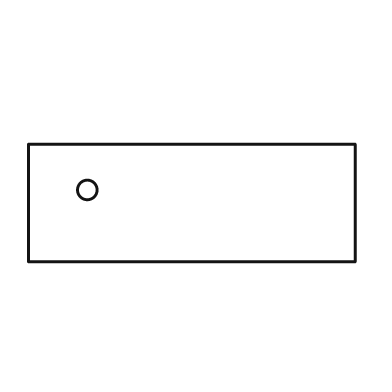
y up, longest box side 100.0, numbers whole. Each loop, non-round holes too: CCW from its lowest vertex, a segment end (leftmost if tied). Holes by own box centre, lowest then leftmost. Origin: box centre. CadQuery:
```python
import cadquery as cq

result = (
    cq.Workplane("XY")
    .moveTo(-50.0, -18.0)
    .lineTo(50.0, -18.0)
    .lineTo(50.0, 18.0)
    .lineTo(-50.0, 18.0)
    .close()
    .moveTo(-32.0, 4.0)
    .circle(3.0)
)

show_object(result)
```